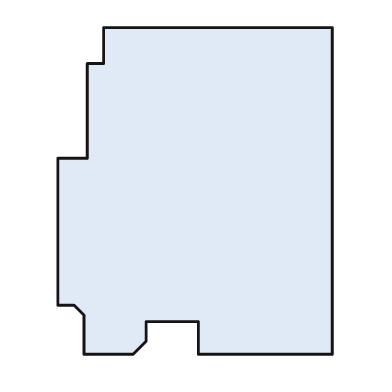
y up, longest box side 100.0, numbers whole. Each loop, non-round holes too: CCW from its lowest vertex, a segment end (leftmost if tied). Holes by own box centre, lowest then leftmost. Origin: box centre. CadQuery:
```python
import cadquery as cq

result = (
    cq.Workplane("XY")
    .moveTo(-34.0, -50.0)
    .lineTo(-19.0, -50.0)
    .lineTo(-15.0, -46.0)
    .lineTo(-15.0, -40.0)
    .lineTo(1.0, -40.0)
    .lineTo(1.0, -50.0)
    .lineTo(42.0, -50.0)
    .lineTo(42.0, 50.0)
    .lineTo(-28.0, 50.0)
    .lineTo(-28.0, 39.0)
    .lineTo(-33.0, 39.0)
    .lineTo(-33.0, 10.0)
    .lineTo(-42.0, 10.0)
    .lineTo(-42.0, -35.0)
    .lineTo(-37.0, -35.0)
    .lineTo(-34.0, -38.0)
    .close()
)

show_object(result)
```